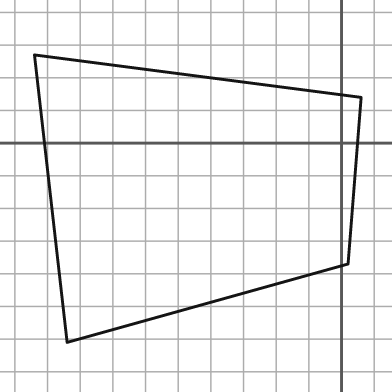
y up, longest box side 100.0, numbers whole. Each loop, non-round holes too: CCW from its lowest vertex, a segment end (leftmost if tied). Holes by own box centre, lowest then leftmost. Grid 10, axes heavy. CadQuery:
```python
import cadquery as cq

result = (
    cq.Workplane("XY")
    .moveTo(-84.0, -61.0)
    .lineTo(2.0, -37.0)
    .lineTo(6.0, 14.0)
    .lineTo(-94.0, 27.0)
    .close()
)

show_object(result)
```